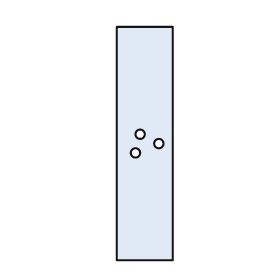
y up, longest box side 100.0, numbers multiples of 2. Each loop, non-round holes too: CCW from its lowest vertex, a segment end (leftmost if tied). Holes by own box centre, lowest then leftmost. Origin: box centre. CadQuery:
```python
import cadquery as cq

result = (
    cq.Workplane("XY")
    .moveTo(-12.0, -50.0)
    .lineTo(12.0, -50.0)
    .lineTo(12.0, 50.0)
    .lineTo(-12.0, 50.0)
    .close()
    .moveTo(-4.0, -4.0)
    .circle(2.0)
    .moveTo(6.0, 0.0)
    .circle(2.0)
    .moveTo(-2.0, 4.0)
    .circle(2.0)
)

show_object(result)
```